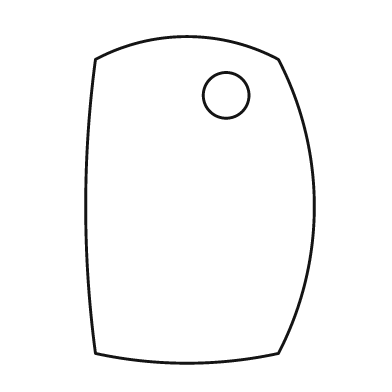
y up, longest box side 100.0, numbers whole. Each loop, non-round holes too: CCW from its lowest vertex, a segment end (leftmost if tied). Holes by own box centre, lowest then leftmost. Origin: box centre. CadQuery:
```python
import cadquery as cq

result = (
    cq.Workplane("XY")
    .moveTo(-32.0, -47.0)
    .threePointArc((-4.0, -50.0), (24.0, -47.0))
    .threePointArc((35.0, -2.0), (24.0, 43.0))
    .threePointArc((-4.0, 50.0), (-32.0, 43.0))
    .threePointArc((-35.0, -2.0), (-32.0, -47.0))
    .close()
    .moveTo(8.0, 32.0)
    .circle(7.0)
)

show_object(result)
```